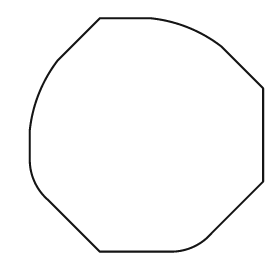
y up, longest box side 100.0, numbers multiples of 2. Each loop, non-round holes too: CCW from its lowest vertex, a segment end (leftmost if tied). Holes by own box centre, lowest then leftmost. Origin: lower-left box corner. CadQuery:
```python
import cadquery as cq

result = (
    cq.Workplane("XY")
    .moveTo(30.0, 0.0)
    .lineTo(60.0, 0.0)
    .threePointArc((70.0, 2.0), (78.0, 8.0))
    .lineTo(100.0, 30.0)
    .lineTo(100.0, 70.0)
    .lineTo(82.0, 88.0)
    .threePointArc((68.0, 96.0), (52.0, 100.0))
    .lineTo(30.0, 100.0)
    .lineTo(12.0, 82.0)
    .threePointArc((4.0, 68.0), (0.0, 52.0))
    .lineTo(0.0, 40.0)
    .threePointArc((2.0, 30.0), (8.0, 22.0))
    .close()
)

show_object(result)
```